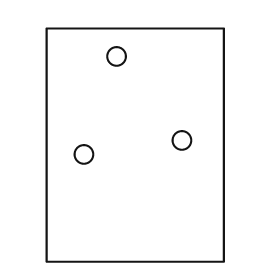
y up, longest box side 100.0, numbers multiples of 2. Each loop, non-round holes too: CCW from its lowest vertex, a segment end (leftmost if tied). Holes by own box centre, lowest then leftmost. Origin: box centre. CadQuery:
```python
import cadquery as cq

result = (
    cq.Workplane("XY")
    .moveTo(-38.0, -50.0)
    .lineTo(38.0, -50.0)
    .lineTo(38.0, 50.0)
    .lineTo(-38.0, 50.0)
    .close()
    .moveTo(-22.0, -4.0)
    .circle(4.0)
    .moveTo(20.0, 2.0)
    .circle(4.0)
    .moveTo(-8.0, 38.0)
    .circle(4.0)
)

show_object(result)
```